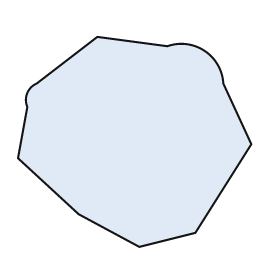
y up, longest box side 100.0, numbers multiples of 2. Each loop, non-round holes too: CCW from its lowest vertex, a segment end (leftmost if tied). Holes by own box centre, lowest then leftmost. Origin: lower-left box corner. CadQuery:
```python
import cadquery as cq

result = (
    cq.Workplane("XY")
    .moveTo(52.0, 0.0)
    .lineTo(76.0, 6.0)
    .lineTo(100.0, 44.0)
    .lineTo(88.0, 70.0)
    .threePointArc((80.0, 84.0), (64.0, 86.0))
    .lineTo(34.0, 90.0)
    .lineTo(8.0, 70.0)
    .threePointArc((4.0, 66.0), (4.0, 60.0))
    .lineTo(0.0, 38.0)
    .lineTo(26.0, 14.0)
    .close()
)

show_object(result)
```